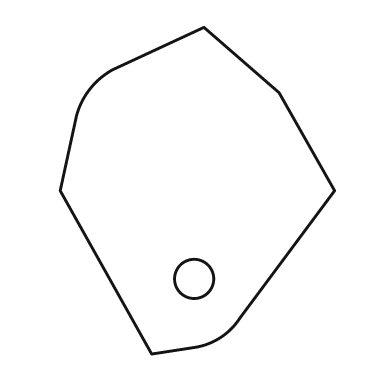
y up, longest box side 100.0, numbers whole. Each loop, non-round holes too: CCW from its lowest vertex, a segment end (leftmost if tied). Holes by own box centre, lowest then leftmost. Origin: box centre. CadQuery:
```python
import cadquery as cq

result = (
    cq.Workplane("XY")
    .moveTo(-14.0, -50.0)
    .lineTo(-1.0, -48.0)
    .threePointArc((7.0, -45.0), (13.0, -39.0))
    .lineTo(42.0, 0.0)
    .lineTo(25.0, 30.0)
    .lineTo(2.0, 50.0)
    .lineTo(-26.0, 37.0)
    .threePointArc((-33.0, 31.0), (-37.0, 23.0))
    .lineTo(-42.0, 0.0)
    .close()
    .moveTo(-1.0, -27.0)
    .circle(6.0)
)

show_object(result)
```